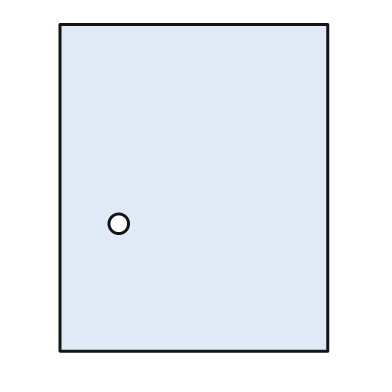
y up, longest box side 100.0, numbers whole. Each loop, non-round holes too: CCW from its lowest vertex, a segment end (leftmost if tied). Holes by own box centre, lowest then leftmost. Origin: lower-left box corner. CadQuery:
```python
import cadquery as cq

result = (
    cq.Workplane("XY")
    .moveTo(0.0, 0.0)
    .lineTo(82.0, 0.0)
    .lineTo(82.0, 100.0)
    .lineTo(0.0, 100.0)
    .close()
    .moveTo(18.0, 39.0)
    .circle(3.0)
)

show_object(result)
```